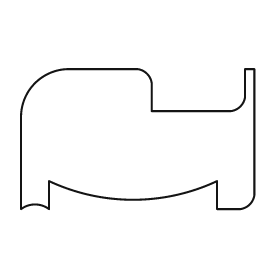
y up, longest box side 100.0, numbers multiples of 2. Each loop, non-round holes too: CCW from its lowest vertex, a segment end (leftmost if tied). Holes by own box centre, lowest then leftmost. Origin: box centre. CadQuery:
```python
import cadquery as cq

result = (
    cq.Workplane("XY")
    .moveTo(-50.0, -30.0)
    .threePointArc((-44.0, -28.0), (-38.0, -30.0))
    .lineTo(-38.0, -18.0)
    .threePointArc((-2.0, -26.0), (34.0, -18.0))
    .lineTo(34.0, -30.0)
    .lineTo(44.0, -30.0)
    .threePointArc((48.0, -28.0), (50.0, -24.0))
    .lineTo(50.0, 30.0)
    .lineTo(46.0, 30.0)
    .lineTo(46.0, 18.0)
    .threePointArc((44.0, 14.0), (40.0, 12.0))
    .lineTo(6.0, 12.0)
    .lineTo(6.0, 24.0)
    .threePointArc((4.0, 28.0), (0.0, 30.0))
    .lineTo(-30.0, 30.0)
    .threePointArc((-44.0, 24.0), (-50.0, 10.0))
    .close()
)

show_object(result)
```